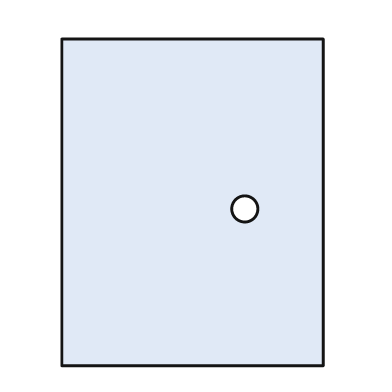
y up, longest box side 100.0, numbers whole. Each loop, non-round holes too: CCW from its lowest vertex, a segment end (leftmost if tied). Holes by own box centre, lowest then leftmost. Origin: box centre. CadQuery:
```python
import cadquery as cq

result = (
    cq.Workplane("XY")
    .moveTo(-40.0, -50.0)
    .lineTo(40.0, -50.0)
    .lineTo(40.0, 50.0)
    .lineTo(-40.0, 50.0)
    .close()
    .moveTo(16.0, -2.0)
    .circle(4.0)
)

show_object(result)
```